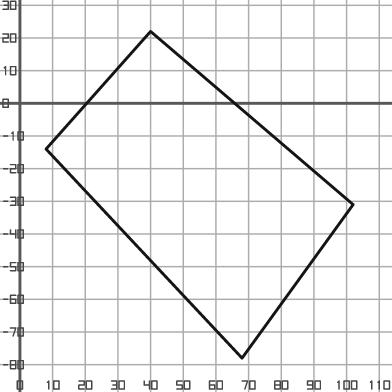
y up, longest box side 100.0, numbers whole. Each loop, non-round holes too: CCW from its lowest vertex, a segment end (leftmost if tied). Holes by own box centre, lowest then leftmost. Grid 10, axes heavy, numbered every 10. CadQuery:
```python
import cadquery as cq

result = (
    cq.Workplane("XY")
    .moveTo(68.0, -78.0)
    .lineTo(102.0, -31.0)
    .lineTo(40.0, 22.0)
    .lineTo(8.0, -14.0)
    .close()
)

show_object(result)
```